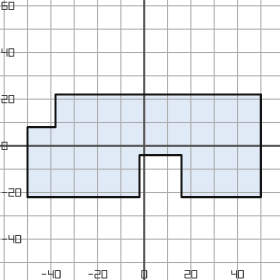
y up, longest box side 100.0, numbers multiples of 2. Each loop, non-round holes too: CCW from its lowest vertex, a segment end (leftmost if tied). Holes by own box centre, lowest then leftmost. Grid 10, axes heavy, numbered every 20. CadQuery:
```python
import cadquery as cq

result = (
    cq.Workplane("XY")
    .moveTo(-50.0, -22.0)
    .lineTo(-2.0, -22.0)
    .lineTo(-2.0, -4.0)
    .lineTo(16.0, -4.0)
    .lineTo(16.0, -22.0)
    .lineTo(50.0, -22.0)
    .lineTo(50.0, 22.0)
    .lineTo(-38.0, 22.0)
    .lineTo(-38.0, 8.0)
    .lineTo(-50.0, 8.0)
    .close()
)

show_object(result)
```